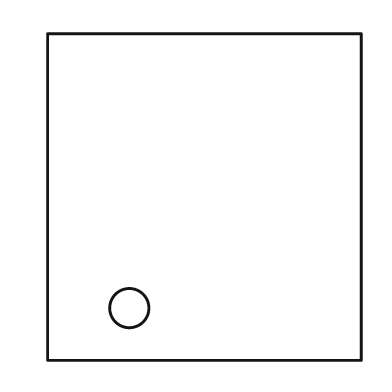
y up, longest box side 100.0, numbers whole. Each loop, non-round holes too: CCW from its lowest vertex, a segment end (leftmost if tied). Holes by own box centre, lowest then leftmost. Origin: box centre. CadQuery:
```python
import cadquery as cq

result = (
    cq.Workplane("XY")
    .moveTo(-48.0, -50.0)
    .lineTo(48.0, -50.0)
    .lineTo(48.0, 50.0)
    .lineTo(-48.0, 50.0)
    .close()
    .moveTo(-23.0, -34.0)
    .circle(6.0)
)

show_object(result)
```